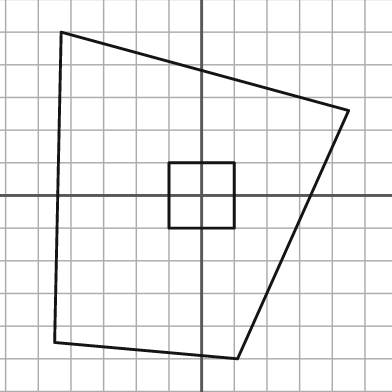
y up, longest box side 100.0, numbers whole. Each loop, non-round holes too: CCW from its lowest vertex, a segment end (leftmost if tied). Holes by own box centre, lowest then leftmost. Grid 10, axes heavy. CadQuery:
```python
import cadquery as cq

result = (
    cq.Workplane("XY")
    .moveTo(11.0, -50.0)
    .lineTo(45.0, 26.0)
    .lineTo(-43.0, 50.0)
    .lineTo(-45.0, -45.0)
    .close()
    .moveTo(-10.0, -10.0)
    .lineTo(10.0, -10.0)
    .lineTo(10.0, 10.0)
    .lineTo(-10.0, 10.0)
    .close()
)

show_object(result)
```